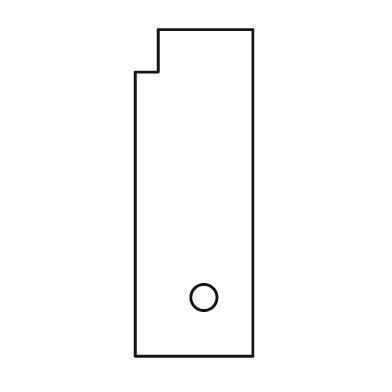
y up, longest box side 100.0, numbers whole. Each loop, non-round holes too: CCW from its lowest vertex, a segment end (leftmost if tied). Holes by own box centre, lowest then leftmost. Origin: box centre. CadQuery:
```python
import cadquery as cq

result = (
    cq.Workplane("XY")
    .moveTo(-18.0, -50.0)
    .lineTo(18.0, -50.0)
    .lineTo(18.0, 50.0)
    .lineTo(-11.0, 50.0)
    .lineTo(-11.0, 37.0)
    .lineTo(-18.0, 37.0)
    .close()
    .moveTo(3.0, -32.0)
    .circle(4.0)
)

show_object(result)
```